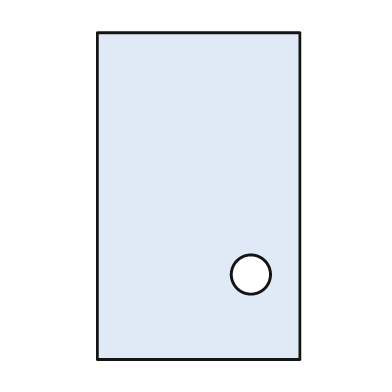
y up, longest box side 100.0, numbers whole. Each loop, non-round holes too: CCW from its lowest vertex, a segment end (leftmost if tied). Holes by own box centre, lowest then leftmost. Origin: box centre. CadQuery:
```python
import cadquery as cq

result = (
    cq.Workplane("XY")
    .moveTo(-31.0, -50.0)
    .lineTo(31.0, -50.0)
    .lineTo(31.0, 50.0)
    .lineTo(-31.0, 50.0)
    .close()
    .moveTo(16.0, -24.0)
    .circle(6.0)
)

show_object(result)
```